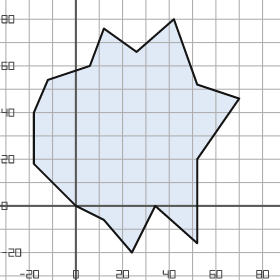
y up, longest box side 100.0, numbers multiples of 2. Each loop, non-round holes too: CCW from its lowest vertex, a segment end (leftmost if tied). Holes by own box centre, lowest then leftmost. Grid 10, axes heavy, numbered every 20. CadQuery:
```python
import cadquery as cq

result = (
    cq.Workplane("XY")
    .moveTo(24.0, -20.0)
    .lineTo(34.0, 0.0)
    .lineTo(52.0, -16.0)
    .lineTo(52.0, 20.0)
    .lineTo(70.0, 46.0)
    .lineTo(52.0, 52.0)
    .lineTo(42.0, 80.0)
    .lineTo(26.0, 66.0)
    .lineTo(12.0, 76.0)
    .lineTo(6.0, 60.0)
    .lineTo(-12.0, 54.0)
    .lineTo(-18.0, 40.0)
    .lineTo(-18.0, 18.0)
    .lineTo(0.0, 0.0)
    .lineTo(12.0, -6.0)
    .close()
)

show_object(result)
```